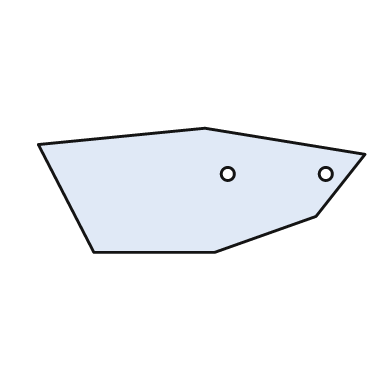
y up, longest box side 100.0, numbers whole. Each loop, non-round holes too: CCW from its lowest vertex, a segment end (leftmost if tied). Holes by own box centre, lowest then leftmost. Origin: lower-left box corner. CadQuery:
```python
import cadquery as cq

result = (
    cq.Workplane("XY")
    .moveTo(17.0, 0.0)
    .lineTo(54.0, 0.0)
    .lineTo(85.0, 11.0)
    .lineTo(100.0, 30.0)
    .lineTo(51.0, 38.0)
    .lineTo(0.0, 33.0)
    .close()
    .moveTo(58.0, 24.0)
    .circle(2.0)
    .moveTo(88.0, 24.0)
    .circle(2.0)
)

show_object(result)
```